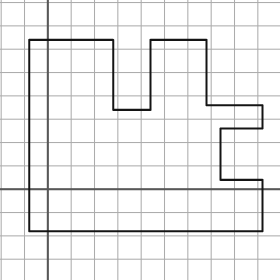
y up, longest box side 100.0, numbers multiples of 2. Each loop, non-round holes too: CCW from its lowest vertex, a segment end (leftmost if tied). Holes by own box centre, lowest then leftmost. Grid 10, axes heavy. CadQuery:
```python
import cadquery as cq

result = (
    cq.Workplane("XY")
    .moveTo(-8.0, -18.0)
    .lineTo(92.0, -18.0)
    .lineTo(92.0, 4.0)
    .lineTo(74.0, 4.0)
    .lineTo(74.0, 26.0)
    .lineTo(92.0, 26.0)
    .lineTo(92.0, 36.0)
    .lineTo(68.0, 36.0)
    .lineTo(68.0, 64.0)
    .lineTo(44.0, 64.0)
    .lineTo(44.0, 34.0)
    .lineTo(28.0, 34.0)
    .lineTo(28.0, 64.0)
    .lineTo(-8.0, 64.0)
    .close()
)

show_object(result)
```